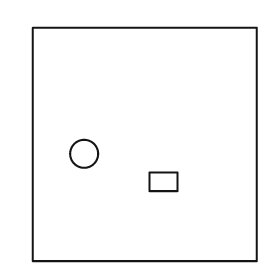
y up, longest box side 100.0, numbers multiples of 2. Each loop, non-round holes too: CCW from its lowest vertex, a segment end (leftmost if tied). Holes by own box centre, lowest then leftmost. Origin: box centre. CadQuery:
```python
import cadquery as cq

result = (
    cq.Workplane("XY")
    .moveTo(-48.0, -50.0)
    .lineTo(48.0, -50.0)
    .lineTo(48.0, 50.0)
    .lineTo(-48.0, 50.0)
    .close()
    .moveTo(2.0, -20.0)
    .lineTo(14.0, -20.0)
    .lineTo(14.0, -12.0)
    .lineTo(2.0, -12.0)
    .close()
    .moveTo(-26.0, -4.0)
    .circle(6.0)
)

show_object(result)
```